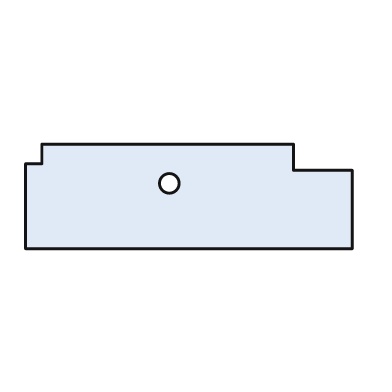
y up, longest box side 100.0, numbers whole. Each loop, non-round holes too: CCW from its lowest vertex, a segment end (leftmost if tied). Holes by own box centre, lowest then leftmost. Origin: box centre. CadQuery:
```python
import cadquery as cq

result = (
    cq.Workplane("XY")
    .moveTo(-50.0, -16.0)
    .lineTo(50.0, -16.0)
    .lineTo(50.0, 8.0)
    .lineTo(32.0, 8.0)
    .lineTo(32.0, 16.0)
    .lineTo(-45.0, 16.0)
    .lineTo(-45.0, 10.0)
    .lineTo(-50.0, 10.0)
    .close()
    .moveTo(-6.0, 4.0)
    .circle(3.0)
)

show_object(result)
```